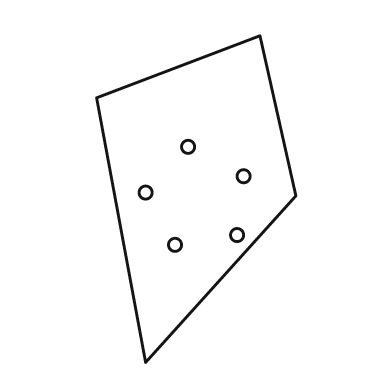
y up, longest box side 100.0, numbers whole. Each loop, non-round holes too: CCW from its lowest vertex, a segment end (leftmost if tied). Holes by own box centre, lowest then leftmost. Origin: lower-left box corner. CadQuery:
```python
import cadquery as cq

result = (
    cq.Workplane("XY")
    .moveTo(15.0, 0.0)
    .lineTo(61.0, 51.0)
    .lineTo(50.0, 100.0)
    .lineTo(0.0, 81.0)
    .close()
    .moveTo(24.0, 36.0)
    .circle(2.0)
    .moveTo(43.0, 39.0)
    .circle(2.0)
    .moveTo(15.0, 52.0)
    .circle(2.0)
    .moveTo(45.0, 57.0)
    .circle(2.0)
    .moveTo(28.0, 66.0)
    .circle(2.0)
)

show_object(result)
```